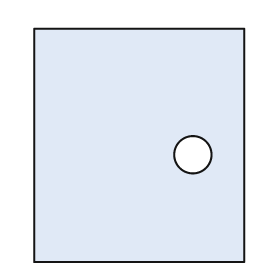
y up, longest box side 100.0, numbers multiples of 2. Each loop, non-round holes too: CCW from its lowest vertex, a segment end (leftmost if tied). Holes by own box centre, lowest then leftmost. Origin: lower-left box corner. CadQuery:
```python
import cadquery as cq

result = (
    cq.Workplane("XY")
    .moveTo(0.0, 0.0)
    .lineTo(90.0, 0.0)
    .lineTo(90.0, 100.0)
    .lineTo(0.0, 100.0)
    .close()
    .moveTo(68.0, 46.0)
    .circle(8.0)
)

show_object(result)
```